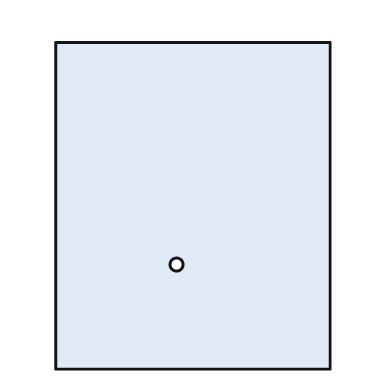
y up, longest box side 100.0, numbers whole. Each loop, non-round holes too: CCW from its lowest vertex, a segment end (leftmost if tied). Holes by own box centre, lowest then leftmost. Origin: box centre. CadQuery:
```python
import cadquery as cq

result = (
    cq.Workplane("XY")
    .moveTo(-42.0, -50.0)
    .lineTo(42.0, -50.0)
    .lineTo(42.0, 50.0)
    .lineTo(-42.0, 50.0)
    .close()
    .moveTo(-5.0, -18.0)
    .circle(2.0)
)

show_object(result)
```